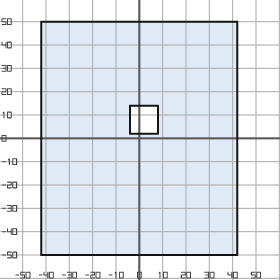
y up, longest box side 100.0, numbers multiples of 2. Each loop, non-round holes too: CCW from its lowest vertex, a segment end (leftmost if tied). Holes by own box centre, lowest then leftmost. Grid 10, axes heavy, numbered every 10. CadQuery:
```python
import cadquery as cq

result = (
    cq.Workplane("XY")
    .moveTo(-42.0, -50.0)
    .lineTo(42.0, -50.0)
    .lineTo(42.0, 50.0)
    .lineTo(-42.0, 50.0)
    .close()
    .moveTo(-4.0, 2.0)
    .lineTo(8.0, 2.0)
    .lineTo(8.0, 14.0)
    .lineTo(-4.0, 14.0)
    .close()
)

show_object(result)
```